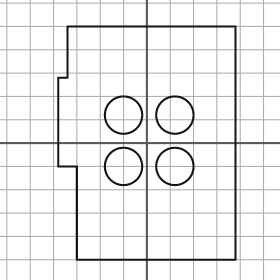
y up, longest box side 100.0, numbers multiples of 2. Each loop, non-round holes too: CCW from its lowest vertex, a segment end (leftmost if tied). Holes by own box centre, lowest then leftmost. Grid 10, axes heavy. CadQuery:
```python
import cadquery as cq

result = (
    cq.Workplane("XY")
    .moveTo(-30.0, -50.0)
    .lineTo(38.0, -50.0)
    .lineTo(38.0, 50.0)
    .lineTo(-34.0, 50.0)
    .lineTo(-34.0, 28.0)
    .lineTo(-38.0, 28.0)
    .lineTo(-38.0, -10.0)
    .lineTo(-30.0, -10.0)
    .close()
    .moveTo(-10.0, -10.0)
    .circle(8.0)
    .moveTo(12.0, -10.0)
    .circle(8.0)
    .moveTo(-10.0, 12.0)
    .circle(8.0)
    .moveTo(12.0, 12.0)
    .circle(8.0)
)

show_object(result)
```